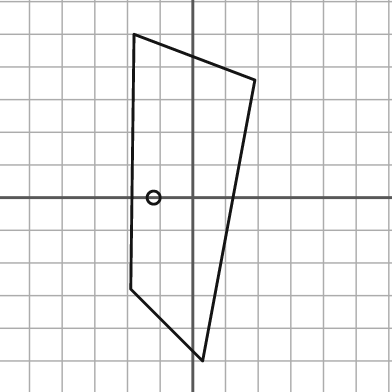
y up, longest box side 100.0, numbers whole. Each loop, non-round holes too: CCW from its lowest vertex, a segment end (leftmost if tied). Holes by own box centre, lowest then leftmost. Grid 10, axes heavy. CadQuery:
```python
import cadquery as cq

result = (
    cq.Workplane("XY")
    .moveTo(3.0, -50.0)
    .lineTo(19.0, 36.0)
    .lineTo(-18.0, 50.0)
    .lineTo(-19.0, -28.0)
    .close()
    .moveTo(-12.0, 0.0)
    .circle(2.0)
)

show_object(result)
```